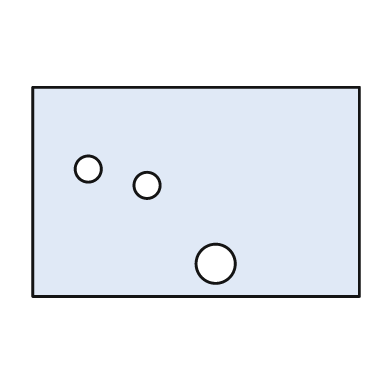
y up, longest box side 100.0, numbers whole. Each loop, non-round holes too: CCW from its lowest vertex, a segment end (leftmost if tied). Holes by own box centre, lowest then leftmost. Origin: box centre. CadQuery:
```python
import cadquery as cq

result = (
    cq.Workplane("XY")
    .moveTo(-50.0, -32.0)
    .lineTo(50.0, -32.0)
    .lineTo(50.0, 32.0)
    .lineTo(-50.0, 32.0)
    .close()
    .moveTo(6.0, -22.0)
    .circle(6.0)
    .moveTo(-15.0, 2.0)
    .circle(4.0)
    .moveTo(-33.0, 7.0)
    .circle(4.0)
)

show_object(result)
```